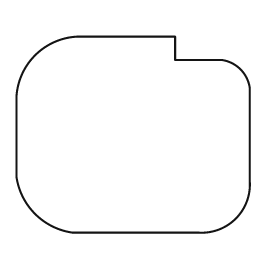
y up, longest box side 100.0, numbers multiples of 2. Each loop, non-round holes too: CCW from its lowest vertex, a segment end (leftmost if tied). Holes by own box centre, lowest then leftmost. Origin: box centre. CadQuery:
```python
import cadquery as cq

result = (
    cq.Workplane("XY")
    .moveTo(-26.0, -42.0)
    .lineTo(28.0, -42.0)
    .threePointArc((44.0, -36.0), (50.0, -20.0))
    .lineTo(50.0, 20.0)
    .threePointArc((46.0, 28.0), (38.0, 32.0))
    .lineTo(18.0, 32.0)
    .lineTo(18.0, 42.0)
    .lineTo(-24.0, 42.0)
    .threePointArc((-42.0, 34.0), (-50.0, 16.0))
    .lineTo(-50.0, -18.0)
    .threePointArc((-42.0, -34.0), (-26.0, -42.0))
    .close()
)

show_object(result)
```